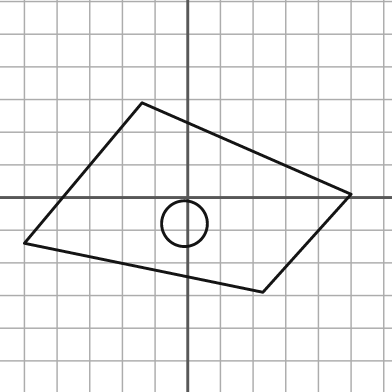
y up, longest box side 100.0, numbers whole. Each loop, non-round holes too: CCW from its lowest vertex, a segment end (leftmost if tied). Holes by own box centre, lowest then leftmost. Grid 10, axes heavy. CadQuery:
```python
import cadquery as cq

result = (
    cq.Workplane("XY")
    .moveTo(23.0, -29.0)
    .lineTo(50.0, 1.0)
    .lineTo(-14.0, 29.0)
    .lineTo(-50.0, -14.0)
    .close()
    .moveTo(-1.0, -8.0)
    .circle(7.0)
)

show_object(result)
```